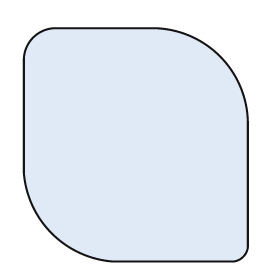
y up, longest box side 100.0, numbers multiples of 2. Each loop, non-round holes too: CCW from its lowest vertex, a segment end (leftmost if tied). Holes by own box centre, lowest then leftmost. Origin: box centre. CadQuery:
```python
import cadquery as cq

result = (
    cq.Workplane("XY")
    .moveTo(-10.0, -50.0)
    .lineTo(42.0, -50.0)
    .threePointArc((46.0, -48.0), (48.0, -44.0))
    .lineTo(48.0, 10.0)
    .threePointArc((36.0, 38.0), (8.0, 50.0))
    .lineTo(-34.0, 50.0)
    .threePointArc((-44.0, 46.0), (-48.0, 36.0))
    .lineTo(-48.0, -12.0)
    .threePointArc((-36.0, -38.0), (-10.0, -50.0))
    .close()
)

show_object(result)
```